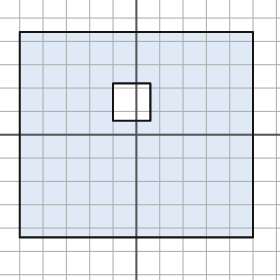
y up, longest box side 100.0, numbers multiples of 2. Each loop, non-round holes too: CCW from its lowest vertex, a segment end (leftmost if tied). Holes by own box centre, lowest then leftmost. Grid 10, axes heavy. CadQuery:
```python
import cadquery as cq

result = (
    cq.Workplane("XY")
    .moveTo(-50.0, -44.0)
    .lineTo(50.0, -44.0)
    .lineTo(50.0, 44.0)
    .lineTo(-50.0, 44.0)
    .close()
    .moveTo(-10.0, 6.0)
    .lineTo(6.0, 6.0)
    .lineTo(6.0, 22.0)
    .lineTo(-10.0, 22.0)
    .close()
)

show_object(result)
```